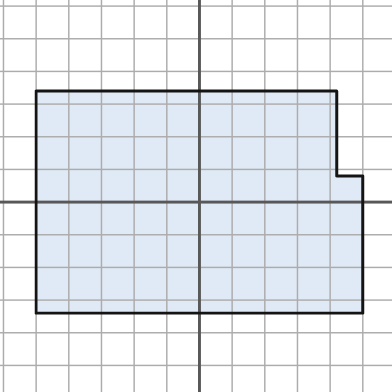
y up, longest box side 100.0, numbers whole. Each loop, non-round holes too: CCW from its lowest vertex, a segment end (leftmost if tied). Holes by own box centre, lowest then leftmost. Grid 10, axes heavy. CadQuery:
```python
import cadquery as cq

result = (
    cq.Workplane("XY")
    .moveTo(-50.0, -34.0)
    .lineTo(50.0, -34.0)
    .lineTo(50.0, 8.0)
    .lineTo(42.0, 8.0)
    .lineTo(42.0, 34.0)
    .lineTo(-50.0, 34.0)
    .close()
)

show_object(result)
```